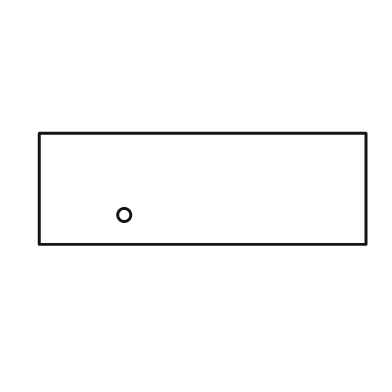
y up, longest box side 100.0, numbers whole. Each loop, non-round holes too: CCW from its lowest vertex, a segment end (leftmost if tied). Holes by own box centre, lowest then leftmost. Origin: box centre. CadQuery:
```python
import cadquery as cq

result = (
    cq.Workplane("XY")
    .moveTo(-50.0, -17.0)
    .lineTo(50.0, -17.0)
    .lineTo(50.0, 17.0)
    .lineTo(-50.0, 17.0)
    .close()
    .moveTo(-24.0, -8.0)
    .circle(2.0)
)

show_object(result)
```